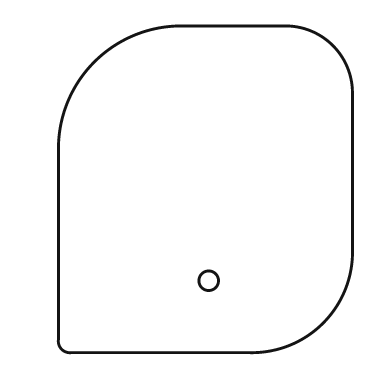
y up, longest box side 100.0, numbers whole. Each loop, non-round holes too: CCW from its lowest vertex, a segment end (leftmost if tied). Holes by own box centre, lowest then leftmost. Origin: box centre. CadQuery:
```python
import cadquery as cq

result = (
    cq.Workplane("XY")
    .moveTo(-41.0, -50.0)
    .lineTo(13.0, -50.0)
    .threePointArc((36.0, -41.0), (45.0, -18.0))
    .lineTo(45.0, 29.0)
    .threePointArc((39.0, 44.0), (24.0, 50.0))
    .lineTo(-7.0, 50.0)
    .threePointArc((-34.0, 39.0), (-45.0, 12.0))
    .lineTo(-45.0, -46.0)
    .threePointArc((-44.0, -49.0), (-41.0, -50.0))
    .close()
    .moveTo(1.0, -28.0)
    .circle(3.0)
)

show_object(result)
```